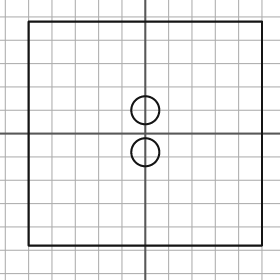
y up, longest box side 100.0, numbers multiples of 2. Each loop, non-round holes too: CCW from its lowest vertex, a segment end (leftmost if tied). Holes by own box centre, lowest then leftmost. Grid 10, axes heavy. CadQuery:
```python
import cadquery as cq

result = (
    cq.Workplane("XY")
    .moveTo(-50.0, -48.0)
    .lineTo(50.0, -48.0)
    .lineTo(50.0, 48.0)
    .lineTo(-50.0, 48.0)
    .close()
    .moveTo(0.0, -8.0)
    .circle(6.0)
    .moveTo(0.0, 10.0)
    .circle(6.0)
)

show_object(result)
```